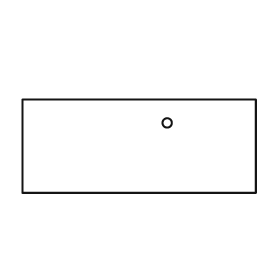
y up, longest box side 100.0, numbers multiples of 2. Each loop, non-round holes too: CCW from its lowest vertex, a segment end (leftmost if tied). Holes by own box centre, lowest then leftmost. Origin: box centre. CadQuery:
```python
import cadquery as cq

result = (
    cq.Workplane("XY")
    .moveTo(-50.0, -20.0)
    .lineTo(50.0, -20.0)
    .lineTo(50.0, 20.0)
    .lineTo(-50.0, 20.0)
    .close()
    .moveTo(12.0, 10.0)
    .circle(2.0)
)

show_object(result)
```